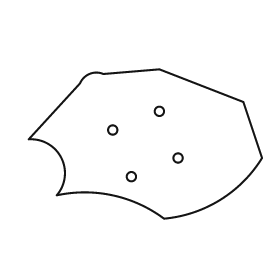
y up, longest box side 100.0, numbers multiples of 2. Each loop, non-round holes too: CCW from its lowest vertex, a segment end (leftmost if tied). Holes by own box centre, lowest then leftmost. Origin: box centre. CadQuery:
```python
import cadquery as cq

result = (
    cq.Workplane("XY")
    .moveTo(8.0, -32.0)
    .threePointArc((32.0, -24.0), (50.0, -6.0))
    .lineTo(42.0, 18.0)
    .lineTo(6.0, 32.0)
    .lineTo(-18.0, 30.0)
    .threePointArc((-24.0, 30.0), (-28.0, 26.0))
    .lineTo(-50.0, 2.0)
    .threePointArc((-36.0, -6.0), (-38.0, -22.0))
    .threePointArc((-14.0, -22.0), (8.0, -32.0))
    .close()
    .moveTo(-6.0, -14.0)
    .circle(2.0)
    .moveTo(14.0, -6.0)
    .circle(2.0)
    .moveTo(-14.0, 6.0)
    .circle(2.0)
    .moveTo(6.0, 14.0)
    .circle(2.0)
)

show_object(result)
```